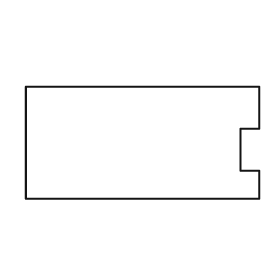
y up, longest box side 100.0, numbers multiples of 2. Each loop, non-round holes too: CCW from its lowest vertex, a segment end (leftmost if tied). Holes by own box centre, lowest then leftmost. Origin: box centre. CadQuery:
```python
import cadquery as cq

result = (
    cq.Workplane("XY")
    .moveTo(-50.0, -24.0)
    .lineTo(50.0, -24.0)
    .lineTo(50.0, -12.0)
    .lineTo(42.0, -12.0)
    .lineTo(42.0, 6.0)
    .lineTo(50.0, 6.0)
    .lineTo(50.0, 24.0)
    .lineTo(-50.0, 24.0)
    .close()
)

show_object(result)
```